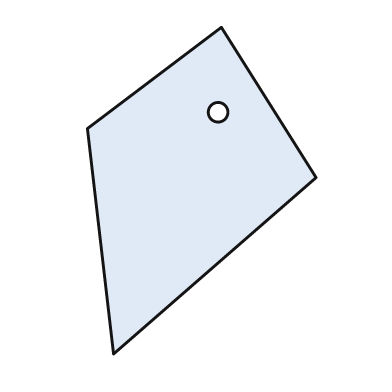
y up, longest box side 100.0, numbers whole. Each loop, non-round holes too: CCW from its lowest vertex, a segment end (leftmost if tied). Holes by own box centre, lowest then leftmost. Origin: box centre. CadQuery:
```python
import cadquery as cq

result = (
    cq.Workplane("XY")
    .moveTo(-27.0, -50.0)
    .lineTo(35.0, 4.0)
    .lineTo(6.0, 50.0)
    .lineTo(-35.0, 19.0)
    .close()
    .moveTo(5.0, 24.0)
    .circle(3.0)
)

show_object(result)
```